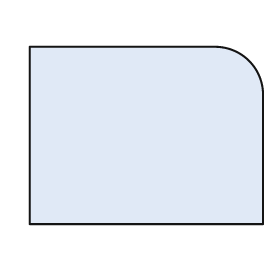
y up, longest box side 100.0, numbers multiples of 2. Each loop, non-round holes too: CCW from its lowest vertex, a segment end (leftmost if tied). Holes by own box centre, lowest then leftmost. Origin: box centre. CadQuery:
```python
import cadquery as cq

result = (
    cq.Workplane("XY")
    .moveTo(-50.0, -38.0)
    .lineTo(50.0, -38.0)
    .lineTo(50.0, 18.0)
    .threePointArc((44.0, 32.0), (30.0, 38.0))
    .lineTo(-50.0, 38.0)
    .close()
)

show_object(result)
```